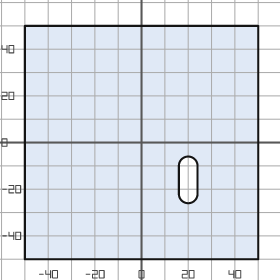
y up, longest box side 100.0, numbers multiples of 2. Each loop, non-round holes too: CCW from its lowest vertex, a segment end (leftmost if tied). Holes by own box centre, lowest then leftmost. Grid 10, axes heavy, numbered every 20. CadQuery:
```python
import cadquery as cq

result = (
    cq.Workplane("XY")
    .moveTo(-50.0, -50.0)
    .lineTo(50.0, -50.0)
    .lineTo(50.0, 50.0)
    .lineTo(-50.0, 50.0)
    .close()
    .moveTo(16.0, -22.0)
    .threePointArc((20.0, -26.0), (24.0, -22.0))
    .lineTo(24.0, -10.0)
    .threePointArc((20.0, -6.0), (16.0, -10.0))
    .close()
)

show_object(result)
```